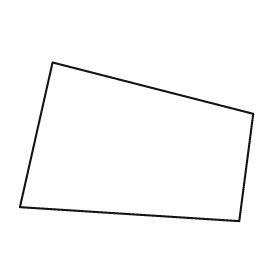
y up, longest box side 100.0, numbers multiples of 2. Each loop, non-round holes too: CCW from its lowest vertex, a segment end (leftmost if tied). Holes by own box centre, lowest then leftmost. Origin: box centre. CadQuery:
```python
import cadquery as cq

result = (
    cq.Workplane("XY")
    .moveTo(44.0, -34.0)
    .lineTo(50.0, 12.0)
    .lineTo(-36.0, 34.0)
    .lineTo(-50.0, -28.0)
    .close()
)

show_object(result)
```